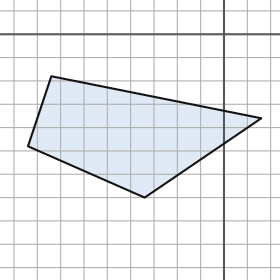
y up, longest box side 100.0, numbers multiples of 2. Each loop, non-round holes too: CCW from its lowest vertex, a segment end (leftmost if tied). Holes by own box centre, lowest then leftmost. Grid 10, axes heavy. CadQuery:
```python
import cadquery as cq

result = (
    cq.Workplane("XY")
    .moveTo(-34.0, -70.0)
    .lineTo(16.0, -36.0)
    .lineTo(-74.0, -18.0)
    .lineTo(-84.0, -48.0)
    .close()
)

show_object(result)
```